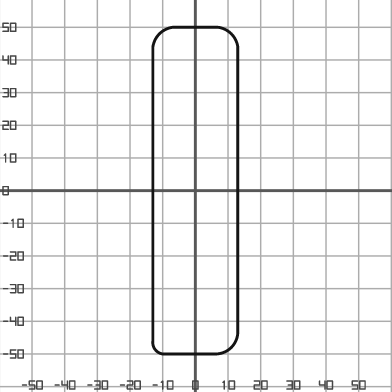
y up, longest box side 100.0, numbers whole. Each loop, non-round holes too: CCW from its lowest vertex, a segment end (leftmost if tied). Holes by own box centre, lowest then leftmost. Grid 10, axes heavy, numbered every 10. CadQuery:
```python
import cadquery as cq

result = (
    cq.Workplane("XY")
    .moveTo(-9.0, -50.0)
    .lineTo(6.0, -50.0)
    .threePointArc((11.0, -48.0), (13.0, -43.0))
    .lineTo(13.0, 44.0)
    .threePointArc((11.0, 48.0), (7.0, 50.0))
    .lineTo(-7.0, 50.0)
    .threePointArc((-11.0, 48.0), (-13.0, 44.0))
    .lineTo(-13.0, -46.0)
    .threePointArc((-12.0, -49.0), (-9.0, -50.0))
    .close()
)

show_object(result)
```